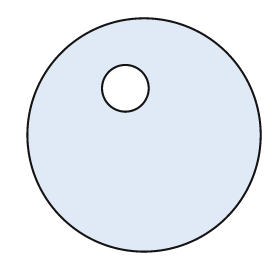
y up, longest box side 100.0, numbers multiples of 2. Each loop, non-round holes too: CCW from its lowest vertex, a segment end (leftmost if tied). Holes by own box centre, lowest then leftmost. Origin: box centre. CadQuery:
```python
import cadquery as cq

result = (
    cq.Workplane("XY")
    .moveTo(0.0, 0.0)
    .circle(50.0)
    .moveTo(-8.0, 20.0)
    .circle(10.0)
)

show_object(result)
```